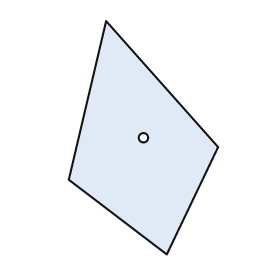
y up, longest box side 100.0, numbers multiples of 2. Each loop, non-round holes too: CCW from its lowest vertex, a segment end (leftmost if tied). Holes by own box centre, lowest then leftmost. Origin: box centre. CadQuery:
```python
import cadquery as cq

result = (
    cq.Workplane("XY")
    .moveTo(10.0, -50.0)
    .lineTo(32.0, -4.0)
    .lineTo(-16.0, 50.0)
    .lineTo(-32.0, -18.0)
    .close()
    .moveTo(0.0, 0.0)
    .circle(2.0)
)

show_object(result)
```